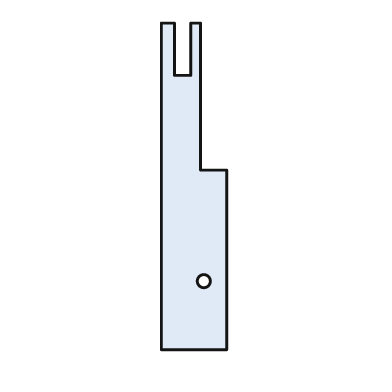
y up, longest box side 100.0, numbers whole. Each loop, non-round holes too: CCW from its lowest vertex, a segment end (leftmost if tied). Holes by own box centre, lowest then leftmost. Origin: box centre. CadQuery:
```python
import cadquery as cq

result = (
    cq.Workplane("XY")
    .moveTo(-10.0, -50.0)
    .lineTo(10.0, -50.0)
    .lineTo(10.0, 5.0)
    .lineTo(2.0, 5.0)
    .lineTo(2.0, 50.0)
    .lineTo(-1.0, 50.0)
    .lineTo(-1.0, 34.0)
    .lineTo(-6.0, 34.0)
    .lineTo(-6.0, 50.0)
    .lineTo(-10.0, 50.0)
    .close()
    .moveTo(3.0, -29.0)
    .circle(2.0)
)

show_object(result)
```